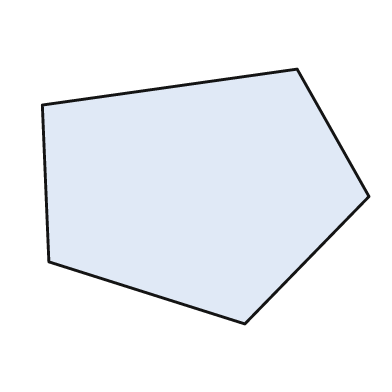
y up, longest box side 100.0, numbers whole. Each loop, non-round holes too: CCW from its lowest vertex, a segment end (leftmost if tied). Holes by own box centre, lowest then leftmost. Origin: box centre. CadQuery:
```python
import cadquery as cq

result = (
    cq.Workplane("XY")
    .moveTo(12.0, -39.0)
    .lineTo(50.0, 0.0)
    .lineTo(28.0, 39.0)
    .lineTo(-50.0, 28.0)
    .lineTo(-48.0, -20.0)
    .close()
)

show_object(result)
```